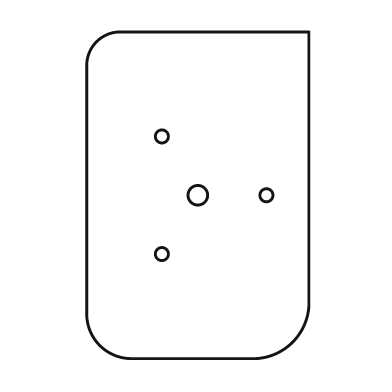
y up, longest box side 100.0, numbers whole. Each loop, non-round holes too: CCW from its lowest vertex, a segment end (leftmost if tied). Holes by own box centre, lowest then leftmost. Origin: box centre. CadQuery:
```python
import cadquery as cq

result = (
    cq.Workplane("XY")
    .moveTo(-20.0, -50.0)
    .lineTo(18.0, -50.0)
    .threePointArc((29.0, -45.0), (34.0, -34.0))
    .lineTo(34.0, 50.0)
    .lineTo(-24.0, 50.0)
    .threePointArc((-31.0, 47.0), (-34.0, 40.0))
    .lineTo(-34.0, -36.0)
    .threePointArc((-30.0, -46.0), (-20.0, -50.0))
    .close()
    .moveTo(-11.0, -18.0)
    .circle(2.0)
    .moveTo(0.0, 0.0)
    .circle(3.0)
    .moveTo(21.0, 0.0)
    .circle(2.0)
    .moveTo(-11.0, 18.0)
    .circle(2.0)
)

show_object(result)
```